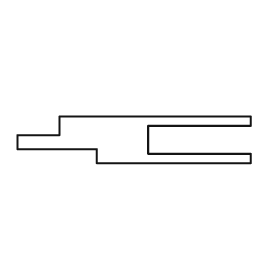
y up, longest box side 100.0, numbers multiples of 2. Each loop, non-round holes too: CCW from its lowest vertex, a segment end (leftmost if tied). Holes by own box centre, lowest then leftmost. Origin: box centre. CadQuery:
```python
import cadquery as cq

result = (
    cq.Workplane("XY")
    .moveTo(-16.0, -10.0)
    .lineTo(50.0, -10.0)
    .lineTo(50.0, -6.0)
    .lineTo(6.0, -6.0)
    .lineTo(6.0, 6.0)
    .lineTo(50.0, 6.0)
    .lineTo(50.0, 10.0)
    .lineTo(-32.0, 10.0)
    .lineTo(-32.0, 2.0)
    .lineTo(-50.0, 2.0)
    .lineTo(-50.0, -4.0)
    .lineTo(-16.0, -4.0)
    .close()
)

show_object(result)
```